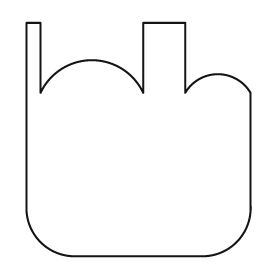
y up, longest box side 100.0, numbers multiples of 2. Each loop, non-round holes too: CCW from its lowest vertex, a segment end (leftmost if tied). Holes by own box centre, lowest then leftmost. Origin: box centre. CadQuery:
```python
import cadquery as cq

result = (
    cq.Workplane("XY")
    .moveTo(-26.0, -50.0)
    .lineTo(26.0, -50.0)
    .threePointArc((42.0, -44.0), (48.0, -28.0))
    .lineTo(48.0, 20.0)
    .threePointArc((34.0, 28.0), (20.0, 20.0))
    .lineTo(20.0, 50.0)
    .lineTo(2.0, 50.0)
    .lineTo(2.0, 20.0)
    .threePointArc((-20.0, 34.0), (-42.0, 20.0))
    .lineTo(-42.0, 50.0)
    .lineTo(-48.0, 50.0)
    .lineTo(-48.0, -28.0)
    .threePointArc((-42.0, -44.0), (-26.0, -50.0))
    .close()
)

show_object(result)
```